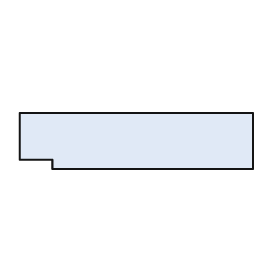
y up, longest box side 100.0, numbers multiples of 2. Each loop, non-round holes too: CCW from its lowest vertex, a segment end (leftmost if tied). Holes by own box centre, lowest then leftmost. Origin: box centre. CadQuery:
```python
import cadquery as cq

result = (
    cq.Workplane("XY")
    .moveTo(-36.0, -12.0)
    .lineTo(50.0, -12.0)
    .lineTo(50.0, 12.0)
    .lineTo(-50.0, 12.0)
    .lineTo(-50.0, -8.0)
    .lineTo(-36.0, -8.0)
    .close()
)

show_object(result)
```